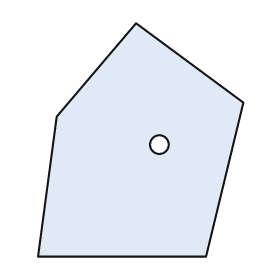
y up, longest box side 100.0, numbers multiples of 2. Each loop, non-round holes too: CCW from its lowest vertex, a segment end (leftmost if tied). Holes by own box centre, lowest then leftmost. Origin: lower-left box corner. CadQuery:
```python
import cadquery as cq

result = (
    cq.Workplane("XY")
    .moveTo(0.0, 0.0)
    .lineTo(72.0, 0.0)
    .lineTo(88.0, 66.0)
    .lineTo(42.0, 100.0)
    .lineTo(8.0, 60.0)
    .close()
    .moveTo(52.0, 48.0)
    .circle(4.0)
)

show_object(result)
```